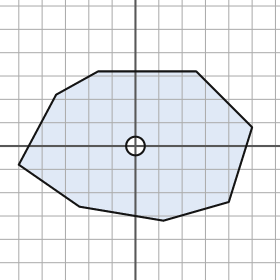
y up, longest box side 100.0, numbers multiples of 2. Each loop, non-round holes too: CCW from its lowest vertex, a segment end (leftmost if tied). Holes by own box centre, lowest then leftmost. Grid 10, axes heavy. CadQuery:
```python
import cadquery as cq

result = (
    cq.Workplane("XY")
    .moveTo(12.0, -32.0)
    .lineTo(40.0, -24.0)
    .lineTo(50.0, 8.0)
    .lineTo(26.0, 32.0)
    .lineTo(-16.0, 32.0)
    .lineTo(-34.0, 22.0)
    .lineTo(-50.0, -8.0)
    .lineTo(-24.0, -26.0)
    .close()
    .moveTo(0.0, 0.0)
    .circle(4.0)
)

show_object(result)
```